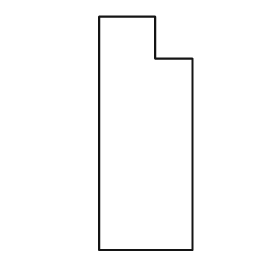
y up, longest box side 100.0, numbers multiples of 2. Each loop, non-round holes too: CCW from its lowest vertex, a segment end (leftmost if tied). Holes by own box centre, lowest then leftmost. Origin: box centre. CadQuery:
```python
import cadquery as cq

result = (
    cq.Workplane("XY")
    .moveTo(-20.0, -50.0)
    .lineTo(20.0, -50.0)
    .lineTo(20.0, 32.0)
    .lineTo(4.0, 32.0)
    .lineTo(4.0, 50.0)
    .lineTo(-20.0, 50.0)
    .close()
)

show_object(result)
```